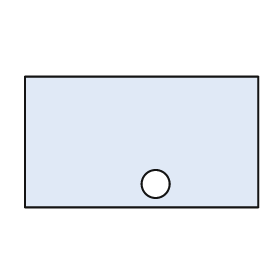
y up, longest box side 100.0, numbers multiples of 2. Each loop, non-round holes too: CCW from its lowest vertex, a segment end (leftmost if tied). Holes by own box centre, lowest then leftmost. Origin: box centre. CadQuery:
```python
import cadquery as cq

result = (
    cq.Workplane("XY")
    .moveTo(-50.0, -28.0)
    .lineTo(50.0, -28.0)
    .lineTo(50.0, 28.0)
    .lineTo(-50.0, 28.0)
    .close()
    .moveTo(6.0, -18.0)
    .circle(6.0)
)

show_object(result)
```